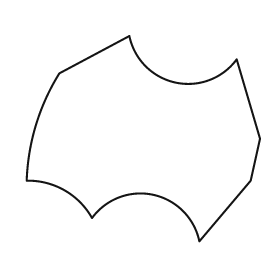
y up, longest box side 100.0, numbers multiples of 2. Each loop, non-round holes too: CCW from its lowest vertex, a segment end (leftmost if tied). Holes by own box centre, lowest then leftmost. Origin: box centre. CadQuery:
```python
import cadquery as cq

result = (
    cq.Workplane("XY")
    .moveTo(24.0, -44.0)
    .lineTo(46.0, -18.0)
    .lineTo(50.0, 0.0)
    .lineTo(40.0, 34.0)
    .threePointArc((14.0, 24.0), (-6.0, 44.0))
    .lineTo(-36.0, 28.0)
    .threePointArc((-46.0, 6.0), (-50.0, -18.0))
    .threePointArc((-34.0, -22.0), (-22.0, -34.0))
    .threePointArc((4.0, -24.0), (24.0, -44.0))
    .close()
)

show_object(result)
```